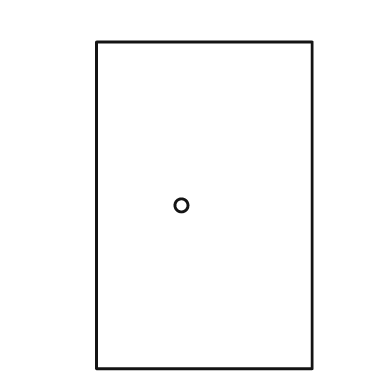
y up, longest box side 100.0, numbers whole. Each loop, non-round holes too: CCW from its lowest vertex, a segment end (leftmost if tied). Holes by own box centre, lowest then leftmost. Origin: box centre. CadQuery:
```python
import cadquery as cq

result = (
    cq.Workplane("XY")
    .moveTo(-33.0, -50.0)
    .lineTo(33.0, -50.0)
    .lineTo(33.0, 50.0)
    .lineTo(-33.0, 50.0)
    .close()
    .moveTo(-7.0, 0.0)
    .circle(2.0)
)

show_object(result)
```